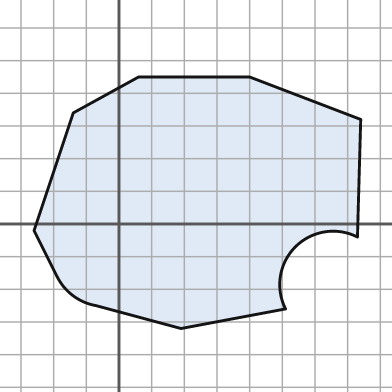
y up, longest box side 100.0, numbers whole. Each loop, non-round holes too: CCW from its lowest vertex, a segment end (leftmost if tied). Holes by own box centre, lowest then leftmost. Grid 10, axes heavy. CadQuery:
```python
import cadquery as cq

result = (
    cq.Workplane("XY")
    .moveTo(19.0, -32.0)
    .lineTo(51.0, -26.0)
    .threePointArc((54.0, -7.0), (73.0, -4.0))
    .lineTo(74.0, 32.0)
    .lineTo(40.0, 45.0)
    .lineTo(6.0, 45.0)
    .lineTo(-14.0, 34.0)
    .lineTo(-26.0, -2.0)
    .lineTo(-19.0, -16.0)
    .threePointArc((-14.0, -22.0), (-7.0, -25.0))
    .close()
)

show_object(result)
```